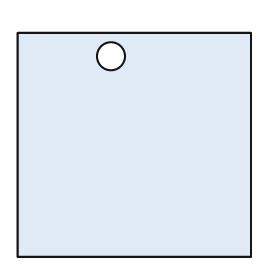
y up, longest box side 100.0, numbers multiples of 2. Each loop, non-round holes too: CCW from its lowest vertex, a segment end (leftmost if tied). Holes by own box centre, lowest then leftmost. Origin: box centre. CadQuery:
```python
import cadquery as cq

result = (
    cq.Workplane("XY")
    .moveTo(-50.0, -48.0)
    .lineTo(50.0, -48.0)
    .lineTo(50.0, 48.0)
    .lineTo(-50.0, 48.0)
    .close()
    .moveTo(-10.0, 38.0)
    .circle(6.0)
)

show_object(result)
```